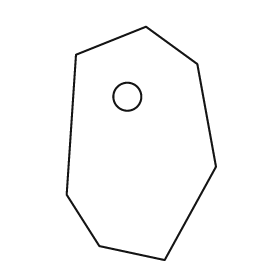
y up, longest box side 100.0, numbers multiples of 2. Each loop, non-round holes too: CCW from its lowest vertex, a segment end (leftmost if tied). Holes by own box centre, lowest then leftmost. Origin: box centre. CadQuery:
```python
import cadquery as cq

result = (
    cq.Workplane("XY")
    .moveTo(10.0, -50.0)
    .lineTo(32.0, -10.0)
    .lineTo(24.0, 34.0)
    .lineTo(2.0, 50.0)
    .lineTo(-28.0, 38.0)
    .lineTo(-32.0, -22.0)
    .lineTo(-18.0, -44.0)
    .close()
    .moveTo(-6.0, 20.0)
    .circle(6.0)
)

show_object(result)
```